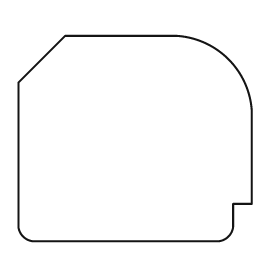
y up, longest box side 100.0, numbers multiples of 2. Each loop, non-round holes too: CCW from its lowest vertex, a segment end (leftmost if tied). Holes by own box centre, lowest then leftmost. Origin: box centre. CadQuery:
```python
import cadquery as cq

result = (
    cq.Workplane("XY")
    .moveTo(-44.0, -44.0)
    .lineTo(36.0, -44.0)
    .threePointArc((40.0, -42.0), (42.0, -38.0))
    .lineTo(42.0, -28.0)
    .lineTo(50.0, -28.0)
    .lineTo(50.0, 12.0)
    .threePointArc((40.0, 34.0), (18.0, 44.0))
    .lineTo(-30.0, 44.0)
    .lineTo(-50.0, 24.0)
    .lineTo(-50.0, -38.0)
    .threePointArc((-48.0, -42.0), (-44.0, -44.0))
    .close()
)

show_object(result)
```